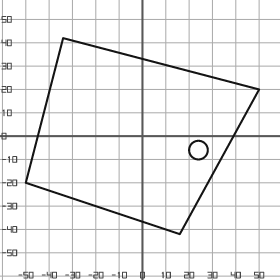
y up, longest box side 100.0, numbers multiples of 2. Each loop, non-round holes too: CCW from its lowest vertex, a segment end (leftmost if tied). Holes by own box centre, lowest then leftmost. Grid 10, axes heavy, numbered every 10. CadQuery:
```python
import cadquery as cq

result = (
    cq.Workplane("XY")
    .moveTo(16.0, -42.0)
    .lineTo(50.0, 20.0)
    .lineTo(-34.0, 42.0)
    .lineTo(-50.0, -20.0)
    .close()
    .moveTo(24.0, -6.0)
    .circle(4.0)
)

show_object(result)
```